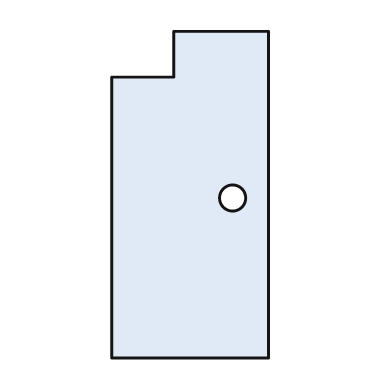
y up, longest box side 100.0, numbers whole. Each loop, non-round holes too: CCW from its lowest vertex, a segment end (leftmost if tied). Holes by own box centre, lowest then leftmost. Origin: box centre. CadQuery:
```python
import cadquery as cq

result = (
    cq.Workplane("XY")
    .moveTo(-24.0, -50.0)
    .lineTo(24.0, -50.0)
    .lineTo(24.0, 50.0)
    .lineTo(-5.0, 50.0)
    .lineTo(-5.0, 36.0)
    .lineTo(-24.0, 36.0)
    .close()
    .moveTo(13.0, -1.0)
    .circle(4.0)
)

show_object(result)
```